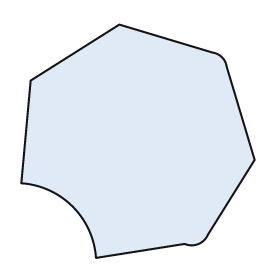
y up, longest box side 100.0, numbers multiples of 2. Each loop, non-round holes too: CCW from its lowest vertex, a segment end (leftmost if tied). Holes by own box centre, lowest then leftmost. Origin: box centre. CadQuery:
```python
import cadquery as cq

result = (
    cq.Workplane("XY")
    .moveTo(-18.0, -50.0)
    .lineTo(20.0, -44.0)
    .threePointArc((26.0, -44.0), (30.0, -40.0))
    .lineTo(50.0, -8.0)
    .lineTo(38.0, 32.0)
    .threePointArc((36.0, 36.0), (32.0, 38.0))
    .lineTo(-8.0, 50.0)
    .lineTo(-46.0, 26.0)
    .lineTo(-50.0, -18.0)
    .threePointArc((-28.0, -28.0), (-18.0, -50.0))
    .close()
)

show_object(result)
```